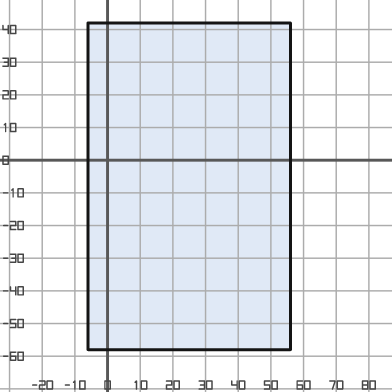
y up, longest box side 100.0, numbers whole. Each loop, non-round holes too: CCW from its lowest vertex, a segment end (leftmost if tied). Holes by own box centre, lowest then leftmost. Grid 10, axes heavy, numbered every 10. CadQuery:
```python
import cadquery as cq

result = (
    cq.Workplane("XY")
    .moveTo(-6.0, -58.0)
    .lineTo(56.0, -58.0)
    .lineTo(56.0, 42.0)
    .lineTo(-6.0, 42.0)
    .close()
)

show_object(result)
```